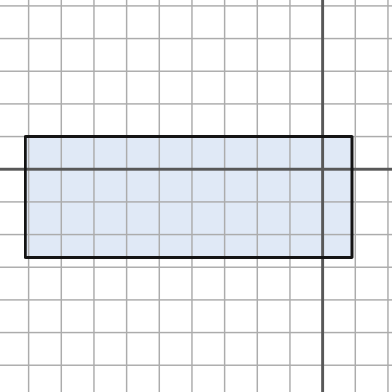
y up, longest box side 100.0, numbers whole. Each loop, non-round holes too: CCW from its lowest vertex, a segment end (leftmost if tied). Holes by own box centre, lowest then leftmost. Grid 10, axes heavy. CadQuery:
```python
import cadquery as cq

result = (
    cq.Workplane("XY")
    .moveTo(-91.0, -27.0)
    .lineTo(9.0, -27.0)
    .lineTo(9.0, 10.0)
    .lineTo(-91.0, 10.0)
    .close()
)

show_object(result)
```